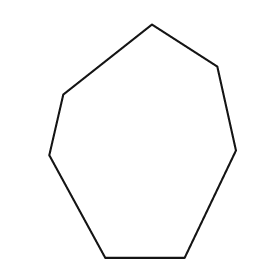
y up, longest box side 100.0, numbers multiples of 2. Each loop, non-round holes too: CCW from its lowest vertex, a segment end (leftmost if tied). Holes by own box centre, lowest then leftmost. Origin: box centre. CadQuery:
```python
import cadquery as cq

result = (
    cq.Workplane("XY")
    .moveTo(-16.0, -50.0)
    .lineTo(18.0, -50.0)
    .lineTo(40.0, -4.0)
    .lineTo(32.0, 32.0)
    .lineTo(4.0, 50.0)
    .lineTo(-34.0, 20.0)
    .lineTo(-40.0, -6.0)
    .close()
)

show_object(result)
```